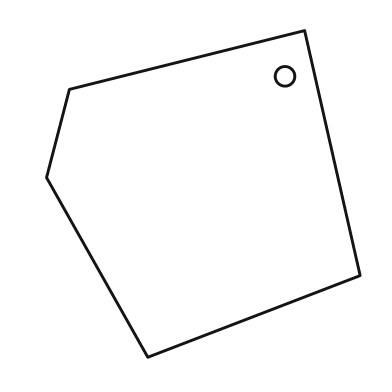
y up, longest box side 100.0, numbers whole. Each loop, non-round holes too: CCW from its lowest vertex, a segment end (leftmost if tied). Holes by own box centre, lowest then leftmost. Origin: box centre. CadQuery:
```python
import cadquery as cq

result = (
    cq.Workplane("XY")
    .moveTo(-17.0, -50.0)
    .lineTo(48.0, -25.0)
    .lineTo(31.0, 50.0)
    .lineTo(-41.0, 32.0)
    .lineTo(-48.0, 5.0)
    .close()
    .moveTo(25.0, 36.0)
    .circle(3.0)
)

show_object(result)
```